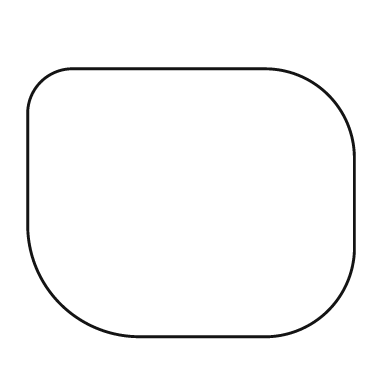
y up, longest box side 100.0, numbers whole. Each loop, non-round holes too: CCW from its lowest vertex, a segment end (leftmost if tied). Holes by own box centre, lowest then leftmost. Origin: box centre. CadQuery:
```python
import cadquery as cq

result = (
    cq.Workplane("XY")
    .moveTo(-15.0, -41.0)
    .lineTo(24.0, -41.0)
    .threePointArc((42.0, -33.0), (50.0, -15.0))
    .lineTo(50.0, 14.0)
    .threePointArc((42.0, 33.0), (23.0, 41.0))
    .lineTo(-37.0, 41.0)
    .threePointArc((-46.0, 37.0), (-50.0, 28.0))
    .lineTo(-50.0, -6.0)
    .threePointArc((-40.0, -31.0), (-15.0, -41.0))
    .close()
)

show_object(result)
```